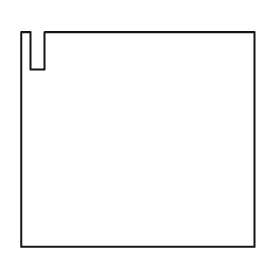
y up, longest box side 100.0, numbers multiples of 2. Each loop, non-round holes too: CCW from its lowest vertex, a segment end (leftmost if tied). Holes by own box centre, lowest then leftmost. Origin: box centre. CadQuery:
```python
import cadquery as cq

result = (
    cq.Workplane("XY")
    .moveTo(-50.0, -46.0)
    .lineTo(50.0, -46.0)
    .lineTo(50.0, 46.0)
    .lineTo(-40.0, 46.0)
    .lineTo(-40.0, 30.0)
    .lineTo(-46.0, 30.0)
    .lineTo(-46.0, 46.0)
    .lineTo(-50.0, 46.0)
    .close()
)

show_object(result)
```